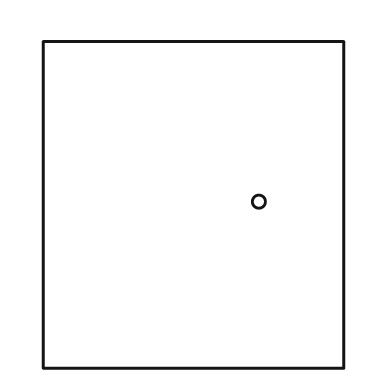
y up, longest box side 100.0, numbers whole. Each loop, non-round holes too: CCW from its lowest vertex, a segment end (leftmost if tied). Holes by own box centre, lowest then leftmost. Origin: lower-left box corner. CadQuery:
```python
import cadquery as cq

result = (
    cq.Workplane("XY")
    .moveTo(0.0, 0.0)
    .lineTo(92.0, 0.0)
    .lineTo(92.0, 100.0)
    .lineTo(0.0, 100.0)
    .close()
    .moveTo(66.0, 51.0)
    .circle(2.0)
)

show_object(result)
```